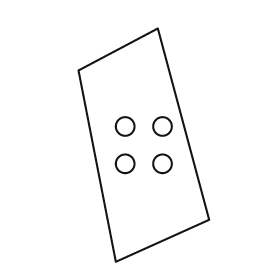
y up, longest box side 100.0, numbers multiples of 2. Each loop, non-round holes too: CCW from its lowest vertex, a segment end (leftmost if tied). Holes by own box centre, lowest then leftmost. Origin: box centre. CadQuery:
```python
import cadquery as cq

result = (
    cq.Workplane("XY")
    .moveTo(-12.0, -50.0)
    .lineTo(28.0, -32.0)
    .lineTo(6.0, 50.0)
    .lineTo(-28.0, 32.0)
    .close()
    .moveTo(-8.0, -8.0)
    .circle(4.0)
    .moveTo(8.0, -8.0)
    .circle(4.0)
    .moveTo(-8.0, 8.0)
    .circle(4.0)
    .moveTo(8.0, 8.0)
    .circle(4.0)
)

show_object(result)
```